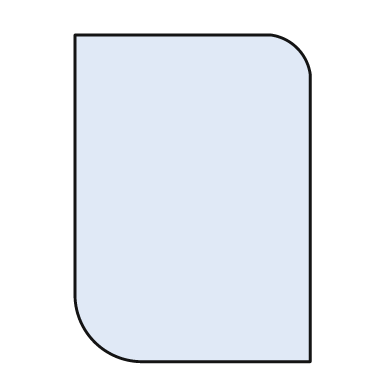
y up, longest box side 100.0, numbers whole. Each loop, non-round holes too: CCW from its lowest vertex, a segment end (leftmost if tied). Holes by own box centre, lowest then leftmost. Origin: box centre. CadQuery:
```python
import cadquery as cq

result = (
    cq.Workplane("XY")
    .moveTo(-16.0, -50.0)
    .lineTo(36.0, -50.0)
    .lineTo(36.0, 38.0)
    .threePointArc((32.0, 46.0), (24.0, 50.0))
    .lineTo(-36.0, 50.0)
    .lineTo(-36.0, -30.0)
    .threePointArc((-30.0, -44.0), (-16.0, -50.0))
    .close()
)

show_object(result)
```